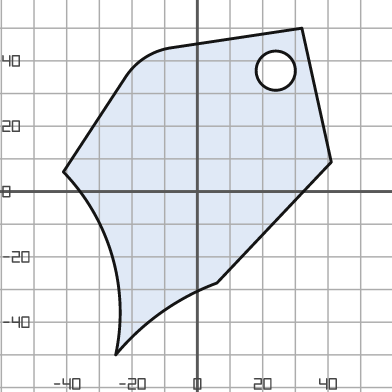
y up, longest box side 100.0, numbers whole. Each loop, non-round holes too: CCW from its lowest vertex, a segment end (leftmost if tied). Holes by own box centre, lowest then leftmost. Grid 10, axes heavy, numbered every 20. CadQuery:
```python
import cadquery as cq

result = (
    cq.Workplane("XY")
    .moveTo(-25.0, -50.0)
    .threePointArc((-11.0, -37.0), (6.0, -28.0))
    .lineTo(41.0, 9.0)
    .lineTo(32.0, 50.0)
    .lineTo(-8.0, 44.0)
    .threePointArc((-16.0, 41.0), (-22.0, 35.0))
    .lineTo(-41.0, 6.0)
    .threePointArc((-26.0, -20.0), (-25.0, -50.0))
    .close()
    .moveTo(24.0, 37.0)
    .circle(6.0)
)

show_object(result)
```